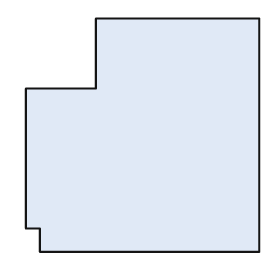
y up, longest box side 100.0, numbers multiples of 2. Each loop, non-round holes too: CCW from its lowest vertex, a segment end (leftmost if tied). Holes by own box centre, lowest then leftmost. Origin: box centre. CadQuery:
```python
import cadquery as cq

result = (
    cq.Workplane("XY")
    .moveTo(-44.0, -50.0)
    .lineTo(50.0, -50.0)
    .lineTo(50.0, 50.0)
    .lineTo(-20.0, 50.0)
    .lineTo(-20.0, 20.0)
    .lineTo(-50.0, 20.0)
    .lineTo(-50.0, -40.0)
    .lineTo(-44.0, -40.0)
    .close()
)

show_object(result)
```